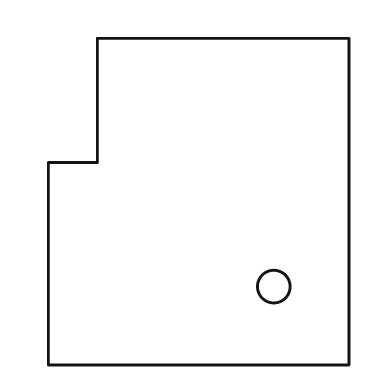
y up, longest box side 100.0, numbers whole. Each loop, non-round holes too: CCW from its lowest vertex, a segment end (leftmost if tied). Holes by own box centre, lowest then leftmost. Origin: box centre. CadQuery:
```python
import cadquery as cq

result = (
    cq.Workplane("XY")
    .moveTo(-46.0, -50.0)
    .lineTo(46.0, -50.0)
    .lineTo(46.0, 50.0)
    .lineTo(-31.0, 50.0)
    .lineTo(-31.0, 12.0)
    .lineTo(-46.0, 12.0)
    .close()
    .moveTo(23.0, -26.0)
    .circle(5.0)
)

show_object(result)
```